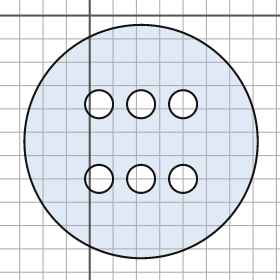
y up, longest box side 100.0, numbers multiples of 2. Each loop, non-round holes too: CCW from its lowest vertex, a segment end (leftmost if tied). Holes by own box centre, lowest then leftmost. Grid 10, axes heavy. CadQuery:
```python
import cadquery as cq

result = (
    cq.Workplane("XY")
    .moveTo(22.0, -54.0)
    .circle(50.0)
    .moveTo(4.0, -70.0)
    .circle(6.0)
    .moveTo(22.0, -70.0)
    .circle(6.0)
    .moveTo(40.0, -70.0)
    .circle(6.0)
    .moveTo(4.0, -38.0)
    .circle(6.0)
    .moveTo(22.0, -38.0)
    .circle(6.0)
    .moveTo(40.0, -38.0)
    .circle(6.0)
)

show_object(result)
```